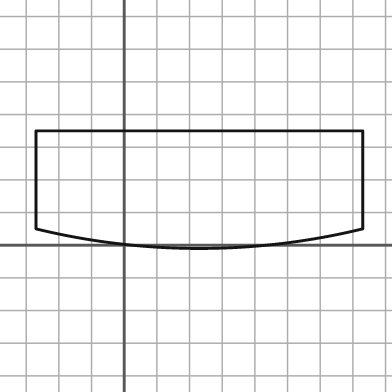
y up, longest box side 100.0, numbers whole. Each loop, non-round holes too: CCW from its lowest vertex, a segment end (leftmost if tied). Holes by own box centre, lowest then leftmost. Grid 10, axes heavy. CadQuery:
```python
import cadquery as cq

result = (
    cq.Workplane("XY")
    .moveTo(-27.0, 5.0)
    .threePointArc((23.0, -1.0), (73.0, 5.0))
    .lineTo(73.0, 35.0)
    .lineTo(-27.0, 35.0)
    .close()
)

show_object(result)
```